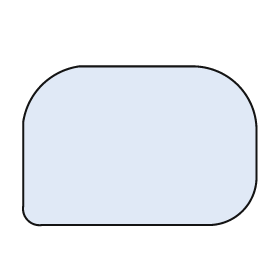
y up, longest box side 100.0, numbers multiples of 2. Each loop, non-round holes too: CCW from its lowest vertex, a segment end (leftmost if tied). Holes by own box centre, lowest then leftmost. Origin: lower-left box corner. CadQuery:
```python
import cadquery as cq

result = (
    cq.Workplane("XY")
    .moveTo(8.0, 0.0)
    .lineTo(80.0, 0.0)
    .threePointArc((94.0, 6.0), (100.0, 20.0))
    .lineTo(100.0, 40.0)
    .threePointArc((92.0, 60.0), (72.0, 68.0))
    .lineTo(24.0, 68.0)
    .threePointArc((8.0, 60.0), (0.0, 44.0))
    .lineTo(0.0, 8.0)
    .threePointArc((2.0, 2.0), (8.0, 0.0))
    .close()
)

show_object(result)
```